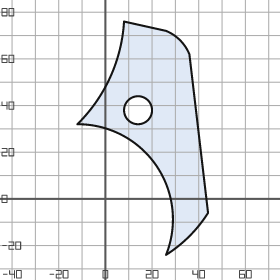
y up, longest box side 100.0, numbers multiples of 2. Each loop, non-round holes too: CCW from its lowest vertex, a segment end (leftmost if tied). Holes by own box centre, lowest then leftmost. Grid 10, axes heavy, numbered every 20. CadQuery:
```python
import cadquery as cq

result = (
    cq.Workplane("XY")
    .moveTo(26.0, -24.0)
    .threePointArc((36.0, -16.0), (44.0, -6.0))
    .lineTo(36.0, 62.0)
    .threePointArc((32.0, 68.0), (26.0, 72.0))
    .lineTo(8.0, 76.0)
    .threePointArc((2.0, 52.0), (-12.0, 32.0))
    .threePointArc((22.0, 14.0), (26.0, -24.0))
    .close()
    .moveTo(14.0, 38.0)
    .circle(6.0)
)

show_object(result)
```